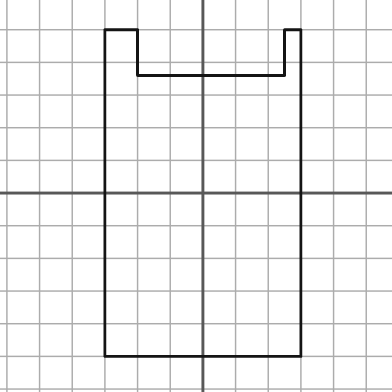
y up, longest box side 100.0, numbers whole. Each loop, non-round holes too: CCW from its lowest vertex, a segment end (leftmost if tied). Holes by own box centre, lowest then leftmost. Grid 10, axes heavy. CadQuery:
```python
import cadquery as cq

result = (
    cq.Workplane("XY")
    .moveTo(-30.0, -50.0)
    .lineTo(30.0, -50.0)
    .lineTo(30.0, 50.0)
    .lineTo(25.0, 50.0)
    .lineTo(25.0, 36.0)
    .lineTo(-20.0, 36.0)
    .lineTo(-20.0, 50.0)
    .lineTo(-30.0, 50.0)
    .close()
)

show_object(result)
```